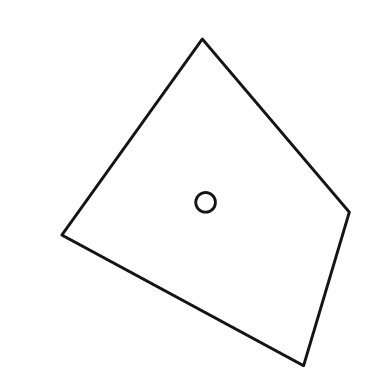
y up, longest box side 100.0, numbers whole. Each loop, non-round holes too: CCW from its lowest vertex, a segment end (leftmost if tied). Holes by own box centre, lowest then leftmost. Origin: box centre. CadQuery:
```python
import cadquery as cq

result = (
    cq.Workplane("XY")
    .moveTo(30.0, -50.0)
    .lineTo(44.0, -3.0)
    .lineTo(-1.0, 50.0)
    .lineTo(-44.0, -10.0)
    .close()
    .moveTo(0.0, 0.0)
    .circle(3.0)
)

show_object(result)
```